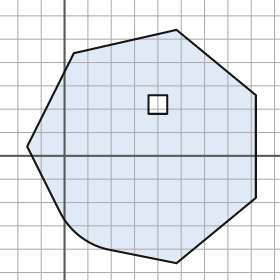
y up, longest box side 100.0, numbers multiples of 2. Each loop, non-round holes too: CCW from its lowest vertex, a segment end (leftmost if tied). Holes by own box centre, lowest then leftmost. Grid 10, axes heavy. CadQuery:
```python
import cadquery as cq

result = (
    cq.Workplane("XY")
    .moveTo(48.0, -46.0)
    .lineTo(82.0, -18.0)
    .lineTo(82.0, 26.0)
    .lineTo(48.0, 54.0)
    .lineTo(4.0, 44.0)
    .lineTo(-16.0, 4.0)
    .lineTo(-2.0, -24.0)
    .threePointArc((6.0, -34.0), (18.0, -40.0))
    .close()
    .moveTo(36.0, 18.0)
    .lineTo(44.0, 18.0)
    .lineTo(44.0, 26.0)
    .lineTo(36.0, 26.0)
    .close()
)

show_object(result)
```